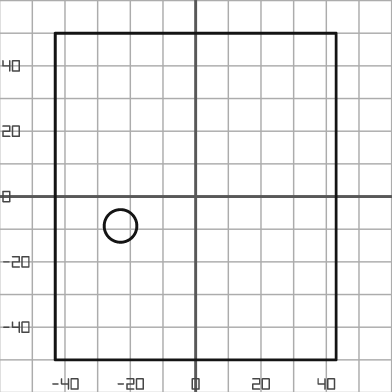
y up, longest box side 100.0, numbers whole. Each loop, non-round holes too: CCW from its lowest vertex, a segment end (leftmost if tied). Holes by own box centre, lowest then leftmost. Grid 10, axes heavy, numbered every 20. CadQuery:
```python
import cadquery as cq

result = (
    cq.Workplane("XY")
    .moveTo(-43.0, -50.0)
    .lineTo(43.0, -50.0)
    .lineTo(43.0, 50.0)
    .lineTo(-43.0, 50.0)
    .close()
    .moveTo(-23.0, -9.0)
    .circle(5.0)
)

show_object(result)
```